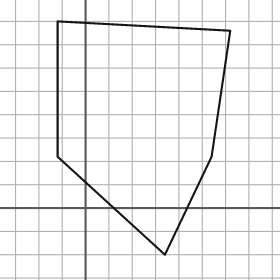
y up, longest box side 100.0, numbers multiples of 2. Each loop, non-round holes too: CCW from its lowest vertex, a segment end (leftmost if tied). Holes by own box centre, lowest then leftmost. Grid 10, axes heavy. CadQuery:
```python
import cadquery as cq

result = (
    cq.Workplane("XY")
    .moveTo(34.0, -20.0)
    .lineTo(54.0, 22.0)
    .lineTo(62.0, 76.0)
    .lineTo(-12.0, 80.0)
    .lineTo(-12.0, 22.0)
    .close()
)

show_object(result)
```